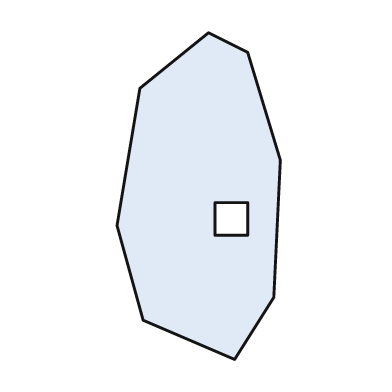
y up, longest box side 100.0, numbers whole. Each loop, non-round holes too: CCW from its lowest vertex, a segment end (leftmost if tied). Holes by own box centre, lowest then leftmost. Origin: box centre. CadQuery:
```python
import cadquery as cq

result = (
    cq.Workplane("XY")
    .moveTo(11.0, -50.0)
    .lineTo(23.0, -31.0)
    .lineTo(25.0, 11.0)
    .lineTo(15.0, 44.0)
    .lineTo(3.0, 50.0)
    .lineTo(-18.0, 33.0)
    .lineTo(-25.0, -9.0)
    .lineTo(-17.0, -38.0)
    .close()
    .moveTo(5.0, -12.0)
    .lineTo(15.0, -12.0)
    .lineTo(15.0, -2.0)
    .lineTo(5.0, -2.0)
    .close()
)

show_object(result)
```